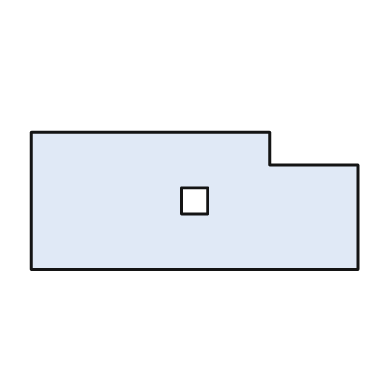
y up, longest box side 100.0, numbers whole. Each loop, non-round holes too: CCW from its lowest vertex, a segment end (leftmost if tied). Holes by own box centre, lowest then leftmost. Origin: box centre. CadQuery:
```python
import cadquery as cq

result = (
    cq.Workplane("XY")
    .moveTo(-50.0, -21.0)
    .lineTo(50.0, -21.0)
    .lineTo(50.0, 11.0)
    .lineTo(23.0, 11.0)
    .lineTo(23.0, 21.0)
    .lineTo(-50.0, 21.0)
    .close()
    .moveTo(-4.0, -4.0)
    .lineTo(4.0, -4.0)
    .lineTo(4.0, 4.0)
    .lineTo(-4.0, 4.0)
    .close()
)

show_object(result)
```